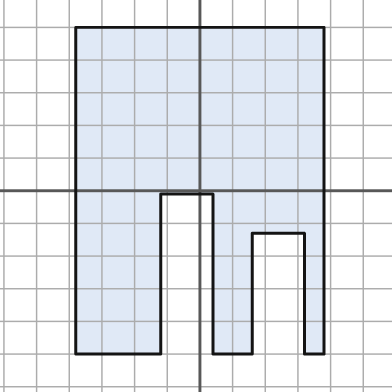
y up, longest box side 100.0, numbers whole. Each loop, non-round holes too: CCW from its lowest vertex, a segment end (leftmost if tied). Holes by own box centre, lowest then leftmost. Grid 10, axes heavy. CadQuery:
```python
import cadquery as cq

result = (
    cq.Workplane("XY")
    .moveTo(-38.0, -50.0)
    .lineTo(-12.0, -50.0)
    .lineTo(-12.0, -1.0)
    .lineTo(4.0, -1.0)
    .lineTo(4.0, -50.0)
    .lineTo(16.0, -50.0)
    .lineTo(16.0, -13.0)
    .lineTo(32.0, -13.0)
    .lineTo(32.0, -50.0)
    .lineTo(38.0, -50.0)
    .lineTo(38.0, 50.0)
    .lineTo(-38.0, 50.0)
    .close()
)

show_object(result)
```